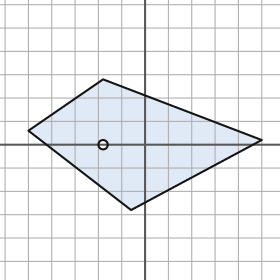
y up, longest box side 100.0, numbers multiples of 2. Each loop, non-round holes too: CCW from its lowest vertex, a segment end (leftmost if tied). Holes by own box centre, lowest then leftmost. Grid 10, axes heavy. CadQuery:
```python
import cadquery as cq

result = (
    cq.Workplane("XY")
    .moveTo(-6.0, -28.0)
    .lineTo(50.0, 2.0)
    .lineTo(-18.0, 28.0)
    .lineTo(-50.0, 6.0)
    .close()
    .moveTo(-18.0, 0.0)
    .circle(2.0)
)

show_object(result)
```